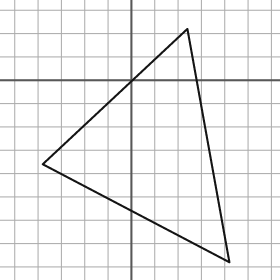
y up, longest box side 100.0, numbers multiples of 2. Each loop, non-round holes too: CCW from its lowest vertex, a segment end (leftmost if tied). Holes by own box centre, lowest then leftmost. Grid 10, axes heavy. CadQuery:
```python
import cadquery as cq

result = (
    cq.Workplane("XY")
    .moveTo(42.0, -78.0)
    .lineTo(24.0, 22.0)
    .lineTo(-38.0, -36.0)
    .close()
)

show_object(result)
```